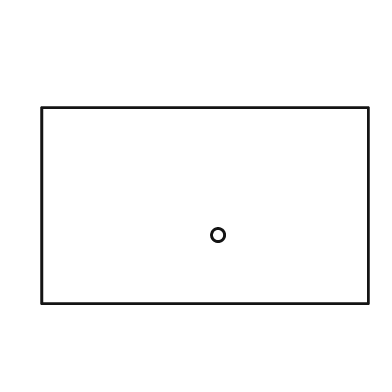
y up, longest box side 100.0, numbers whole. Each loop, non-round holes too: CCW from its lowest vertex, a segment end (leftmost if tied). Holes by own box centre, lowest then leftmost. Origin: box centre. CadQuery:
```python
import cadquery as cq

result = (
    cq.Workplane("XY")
    .moveTo(-50.0, -30.0)
    .lineTo(50.0, -30.0)
    .lineTo(50.0, 30.0)
    .lineTo(-50.0, 30.0)
    .close()
    .moveTo(4.0, -9.0)
    .circle(2.0)
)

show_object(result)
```